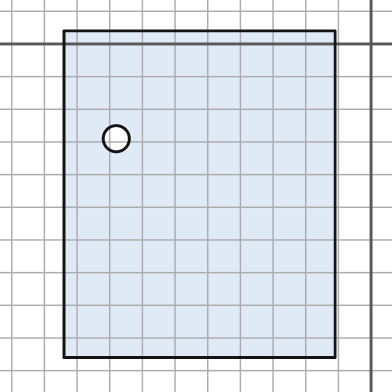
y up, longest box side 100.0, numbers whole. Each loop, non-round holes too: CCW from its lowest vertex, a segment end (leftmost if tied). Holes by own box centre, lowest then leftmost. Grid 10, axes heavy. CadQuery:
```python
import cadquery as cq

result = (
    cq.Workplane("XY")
    .moveTo(-94.0, -96.0)
    .lineTo(-11.0, -96.0)
    .lineTo(-11.0, 4.0)
    .lineTo(-94.0, 4.0)
    .close()
    .moveTo(-78.0, -29.0)
    .circle(4.0)
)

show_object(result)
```